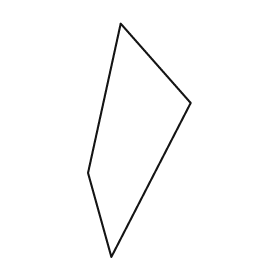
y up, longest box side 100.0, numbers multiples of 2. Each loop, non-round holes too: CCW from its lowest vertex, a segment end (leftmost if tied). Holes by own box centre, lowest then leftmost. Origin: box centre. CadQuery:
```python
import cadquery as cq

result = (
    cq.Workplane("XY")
    .moveTo(-12.0, -50.0)
    .lineTo(22.0, 16.0)
    .lineTo(-8.0, 50.0)
    .lineTo(-22.0, -14.0)
    .close()
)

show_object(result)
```